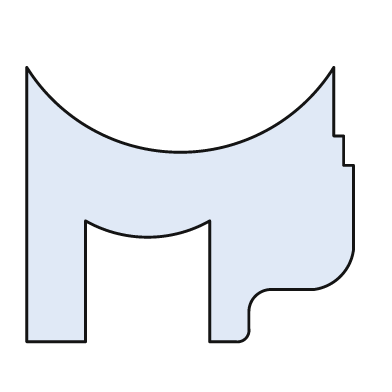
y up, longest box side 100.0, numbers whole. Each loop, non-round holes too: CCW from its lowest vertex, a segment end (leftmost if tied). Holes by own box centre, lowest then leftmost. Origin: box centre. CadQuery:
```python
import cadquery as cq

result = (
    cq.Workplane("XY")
    .moveTo(-50.0, -42.0)
    .lineTo(-32.0, -42.0)
    .lineTo(-32.0, -5.0)
    .threePointArc((-13.0, -10.0), (6.0, -5.0))
    .lineTo(6.0, -42.0)
    .lineTo(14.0, -42.0)
    .threePointArc((17.0, -41.0), (18.0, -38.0))
    .lineTo(18.0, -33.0)
    .threePointArc((20.0, -28.0), (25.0, -26.0))
    .lineTo(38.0, -26.0)
    .threePointArc((46.0, -22.0), (50.0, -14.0))
    .lineTo(50.0, 12.0)
    .lineTo(47.0, 12.0)
    .lineTo(47.0, 21.0)
    .lineTo(44.0, 21.0)
    .lineTo(44.0, 42.0)
    .threePointArc((-3.0, 16.0), (-50.0, 42.0))
    .close()
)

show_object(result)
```